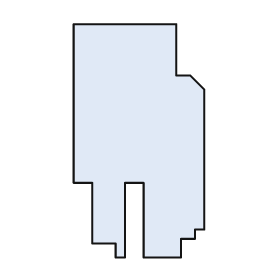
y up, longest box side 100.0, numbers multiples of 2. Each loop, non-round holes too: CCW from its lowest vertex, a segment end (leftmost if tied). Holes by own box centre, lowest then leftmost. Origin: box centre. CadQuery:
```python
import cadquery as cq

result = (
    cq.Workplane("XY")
    .moveTo(-10.0, -50.0)
    .lineTo(-6.0, -50.0)
    .lineTo(-6.0, -18.0)
    .lineTo(2.0, -18.0)
    .lineTo(2.0, -50.0)
    .lineTo(18.0, -50.0)
    .lineTo(18.0, -42.0)
    .lineTo(24.0, -42.0)
    .lineTo(24.0, -38.0)
    .lineTo(28.0, -38.0)
    .lineTo(28.0, 22.0)
    .lineTo(22.0, 28.0)
    .lineTo(16.0, 28.0)
    .lineTo(16.0, 50.0)
    .lineTo(-28.0, 50.0)
    .lineTo(-28.0, -18.0)
    .lineTo(-20.0, -18.0)
    .lineTo(-20.0, -44.0)
    .lineTo(-10.0, -44.0)
    .close()
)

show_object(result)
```